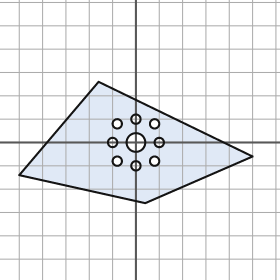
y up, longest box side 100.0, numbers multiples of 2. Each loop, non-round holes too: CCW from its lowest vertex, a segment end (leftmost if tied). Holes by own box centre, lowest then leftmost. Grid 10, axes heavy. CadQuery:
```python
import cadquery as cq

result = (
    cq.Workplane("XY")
    .moveTo(4.0, -26.0)
    .lineTo(50.0, -6.0)
    .lineTo(-16.0, 26.0)
    .lineTo(-50.0, -14.0)
    .close()
    .moveTo(0.0, -10.0)
    .circle(2.0)
    .moveTo(-8.0, -8.0)
    .circle(2.0)
    .moveTo(8.0, -8.0)
    .circle(2.0)
    .moveTo(-10.0, 0.0)
    .circle(2.0)
    .moveTo(0.0, 0.0)
    .circle(4.0)
    .moveTo(10.0, 0.0)
    .circle(2.0)
    .moveTo(-8.0, 8.0)
    .circle(2.0)
    .moveTo(8.0, 8.0)
    .circle(2.0)
    .moveTo(0.0, 10.0)
    .circle(2.0)
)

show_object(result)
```